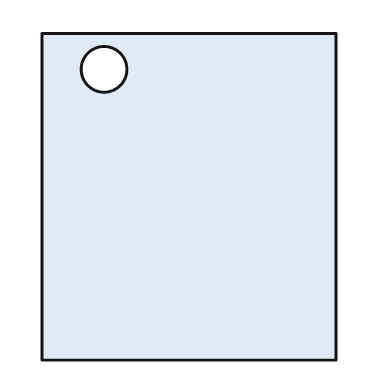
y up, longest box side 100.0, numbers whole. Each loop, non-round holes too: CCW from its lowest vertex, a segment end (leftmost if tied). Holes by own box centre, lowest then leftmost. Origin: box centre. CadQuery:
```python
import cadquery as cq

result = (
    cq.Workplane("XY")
    .moveTo(-45.0, -50.0)
    .lineTo(45.0, -50.0)
    .lineTo(45.0, 50.0)
    .lineTo(-45.0, 50.0)
    .close()
    .moveTo(-26.0, 39.0)
    .circle(7.0)
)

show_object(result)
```